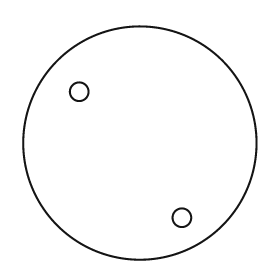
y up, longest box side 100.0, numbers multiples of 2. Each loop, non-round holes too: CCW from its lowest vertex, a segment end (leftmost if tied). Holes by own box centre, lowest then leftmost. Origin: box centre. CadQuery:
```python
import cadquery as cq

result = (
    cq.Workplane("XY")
    .moveTo(0.0, 0.0)
    .circle(50.0)
    .moveTo(18.0, -32.0)
    .circle(4.0)
    .moveTo(-26.0, 22.0)
    .circle(4.0)
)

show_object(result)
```